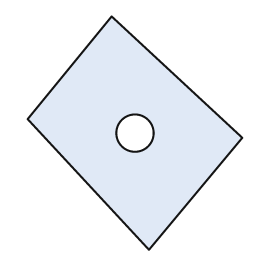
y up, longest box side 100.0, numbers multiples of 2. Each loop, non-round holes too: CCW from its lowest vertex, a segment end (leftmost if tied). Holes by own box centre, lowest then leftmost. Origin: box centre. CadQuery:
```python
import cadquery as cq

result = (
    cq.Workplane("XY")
    .moveTo(6.0, -50.0)
    .lineTo(46.0, -2.0)
    .lineTo(-10.0, 50.0)
    .lineTo(-46.0, 6.0)
    .close()
    .moveTo(0.0, 0.0)
    .circle(8.0)
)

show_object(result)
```